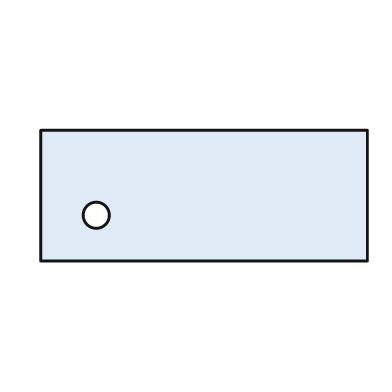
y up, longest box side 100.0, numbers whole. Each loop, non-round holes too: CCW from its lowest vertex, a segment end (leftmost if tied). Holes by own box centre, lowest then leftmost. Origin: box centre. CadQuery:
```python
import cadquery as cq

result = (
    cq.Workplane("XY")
    .moveTo(-50.0, -20.0)
    .lineTo(50.0, -20.0)
    .lineTo(50.0, 20.0)
    .lineTo(-50.0, 20.0)
    .close()
    .moveTo(-33.0, -6.0)
    .circle(4.0)
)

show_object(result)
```